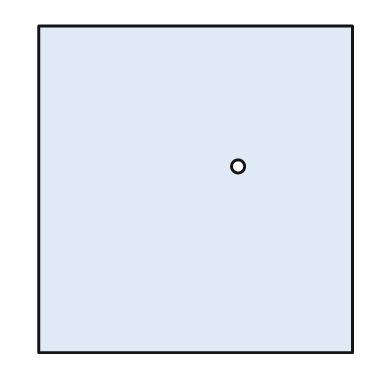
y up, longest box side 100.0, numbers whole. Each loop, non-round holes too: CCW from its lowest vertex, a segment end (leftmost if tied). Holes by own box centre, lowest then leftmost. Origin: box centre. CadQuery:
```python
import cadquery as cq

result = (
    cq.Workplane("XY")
    .moveTo(-48.0, -50.0)
    .lineTo(48.0, -50.0)
    .lineTo(48.0, 50.0)
    .lineTo(-48.0, 50.0)
    .close()
    .moveTo(13.0, 7.0)
    .circle(2.0)
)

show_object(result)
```